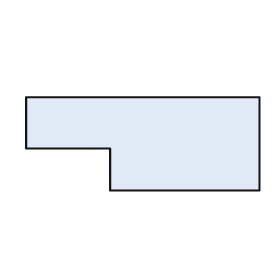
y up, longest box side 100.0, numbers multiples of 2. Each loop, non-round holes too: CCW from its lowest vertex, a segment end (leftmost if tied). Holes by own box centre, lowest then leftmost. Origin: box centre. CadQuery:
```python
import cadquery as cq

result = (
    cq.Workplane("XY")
    .moveTo(-14.0, -20.0)
    .lineTo(50.0, -20.0)
    .lineTo(50.0, 20.0)
    .lineTo(-50.0, 20.0)
    .lineTo(-50.0, -2.0)
    .lineTo(-14.0, -2.0)
    .close()
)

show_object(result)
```